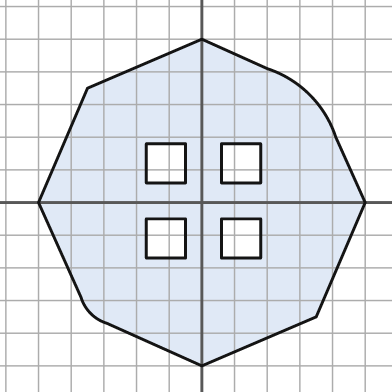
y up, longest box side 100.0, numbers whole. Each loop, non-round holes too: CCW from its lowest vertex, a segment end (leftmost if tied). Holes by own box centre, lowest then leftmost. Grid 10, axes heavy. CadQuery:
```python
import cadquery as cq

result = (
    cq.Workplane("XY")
    .moveTo(0.0, -50.0)
    .lineTo(35.0, -35.0)
    .lineTo(50.0, 0.0)
    .lineTo(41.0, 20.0)
    .threePointArc((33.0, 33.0), (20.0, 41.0))
    .lineTo(0.0, 50.0)
    .lineTo(-35.0, 35.0)
    .lineTo(-50.0, 0.0)
    .lineTo(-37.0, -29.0)
    .threePointArc((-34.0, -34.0), (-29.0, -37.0))
    .close()
    .moveTo(-17.0, -17.0)
    .lineTo(-5.0, -17.0)
    .lineTo(-5.0, -5.0)
    .lineTo(-17.0, -5.0)
    .close()
    .moveTo(6.0, -17.0)
    .lineTo(18.0, -17.0)
    .lineTo(18.0, -5.0)
    .lineTo(6.0, -5.0)
    .close()
    .moveTo(-17.0, 6.0)
    .lineTo(-5.0, 6.0)
    .lineTo(-5.0, 18.0)
    .lineTo(-17.0, 18.0)
    .close()
    .moveTo(6.0, 6.0)
    .lineTo(18.0, 6.0)
    .lineTo(18.0, 18.0)
    .lineTo(6.0, 18.0)
    .close()
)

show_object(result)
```